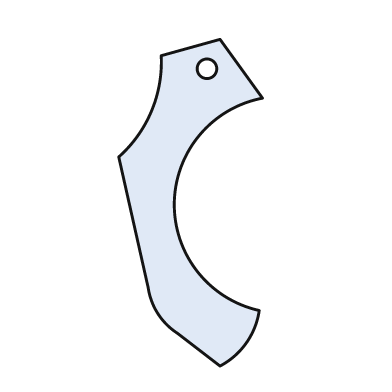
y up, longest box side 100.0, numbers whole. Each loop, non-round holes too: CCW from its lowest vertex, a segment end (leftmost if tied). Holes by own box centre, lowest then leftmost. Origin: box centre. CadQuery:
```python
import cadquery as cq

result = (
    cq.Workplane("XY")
    .moveTo(9.0, -50.0)
    .threePointArc((17.0, -43.0), (21.0, -33.0))
    .threePointArc((-5.0, 0.0), (22.0, 32.0))
    .lineTo(9.0, 50.0)
    .lineTo(-9.0, 45.0)
    .threePointArc((-12.0, 28.0), (-22.0, 14.0))
    .lineTo(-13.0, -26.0)
    .threePointArc((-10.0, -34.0), (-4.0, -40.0))
    .close()
    .moveTo(5.0, 41.0)
    .circle(3.0)
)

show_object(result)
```